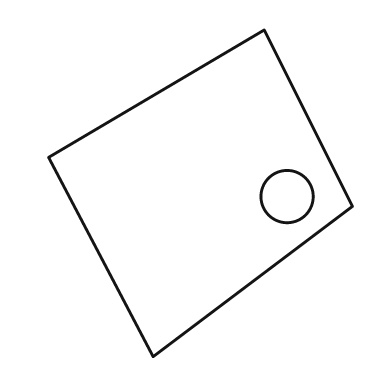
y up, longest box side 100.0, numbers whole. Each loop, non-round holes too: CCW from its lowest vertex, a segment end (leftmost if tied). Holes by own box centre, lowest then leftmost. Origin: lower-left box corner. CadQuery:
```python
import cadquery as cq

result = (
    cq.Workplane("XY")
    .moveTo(32.0, 0.0)
    .lineTo(93.0, 46.0)
    .lineTo(66.0, 100.0)
    .lineTo(0.0, 61.0)
    .close()
    .moveTo(73.0, 49.0)
    .circle(8.0)
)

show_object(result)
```